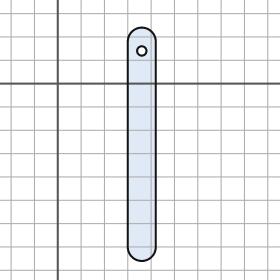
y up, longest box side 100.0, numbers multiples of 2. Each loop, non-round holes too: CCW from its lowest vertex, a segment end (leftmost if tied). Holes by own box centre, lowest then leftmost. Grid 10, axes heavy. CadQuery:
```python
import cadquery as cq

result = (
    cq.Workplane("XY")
    .moveTo(30.0, -70.0)
    .threePointArc((36.0, -76.0), (42.0, -70.0))
    .lineTo(42.0, 18.0)
    .threePointArc((36.0, 24.0), (30.0, 18.0))
    .close()
    .moveTo(36.0, 14.0)
    .circle(2.0)
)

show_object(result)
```